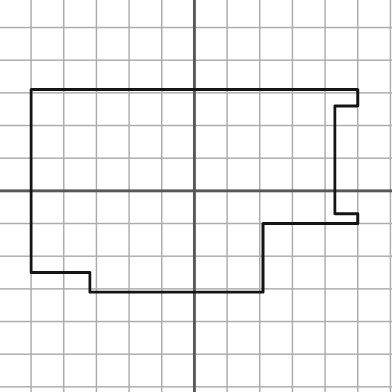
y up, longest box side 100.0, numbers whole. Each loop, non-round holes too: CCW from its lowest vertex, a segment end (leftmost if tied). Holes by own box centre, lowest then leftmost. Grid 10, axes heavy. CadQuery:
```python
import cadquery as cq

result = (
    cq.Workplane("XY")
    .moveTo(-32.0, -31.0)
    .lineTo(21.0, -31.0)
    .lineTo(21.0, -10.0)
    .lineTo(50.0, -10.0)
    .lineTo(50.0, -7.0)
    .lineTo(43.0, -7.0)
    .lineTo(43.0, 26.0)
    .lineTo(50.0, 26.0)
    .lineTo(50.0, 31.0)
    .lineTo(-50.0, 31.0)
    .lineTo(-50.0, -25.0)
    .lineTo(-32.0, -25.0)
    .close()
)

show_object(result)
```